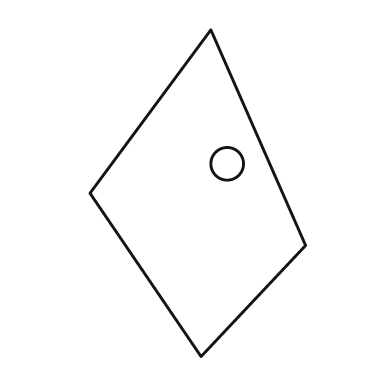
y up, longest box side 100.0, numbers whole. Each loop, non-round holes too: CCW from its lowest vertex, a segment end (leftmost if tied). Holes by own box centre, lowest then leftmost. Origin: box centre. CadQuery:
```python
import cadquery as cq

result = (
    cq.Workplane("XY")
    .moveTo(1.0, -50.0)
    .lineTo(33.0, -16.0)
    .lineTo(4.0, 50.0)
    .lineTo(-33.0, 0.0)
    .close()
    .moveTo(9.0, 9.0)
    .circle(5.0)
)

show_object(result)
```